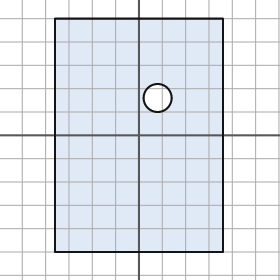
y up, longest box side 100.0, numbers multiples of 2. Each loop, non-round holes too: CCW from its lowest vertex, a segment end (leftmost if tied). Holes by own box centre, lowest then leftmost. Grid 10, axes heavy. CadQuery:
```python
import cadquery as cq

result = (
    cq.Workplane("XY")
    .moveTo(-36.0, -50.0)
    .lineTo(36.0, -50.0)
    .lineTo(36.0, 50.0)
    .lineTo(-36.0, 50.0)
    .close()
    .moveTo(8.0, 16.0)
    .circle(6.0)
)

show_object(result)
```